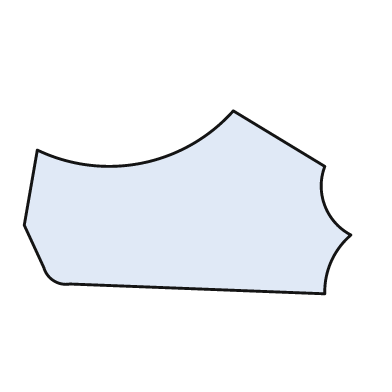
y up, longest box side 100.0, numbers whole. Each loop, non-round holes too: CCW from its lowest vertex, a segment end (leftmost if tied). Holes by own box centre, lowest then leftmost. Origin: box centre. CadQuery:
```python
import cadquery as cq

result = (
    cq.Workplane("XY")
    .moveTo(42.0, -28.0)
    .threePointArc((44.0, -18.0), (50.0, -10.0))
    .threePointArc((42.0, -1.0), (42.0, 11.0))
    .lineTo(14.0, 28.0)
    .threePointArc((-14.0, 12.0), (-46.0, 16.0))
    .lineTo(-50.0, -7.0)
    .lineTo(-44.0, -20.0)
    .threePointArc((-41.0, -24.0), (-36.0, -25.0))
    .close()
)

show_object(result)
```